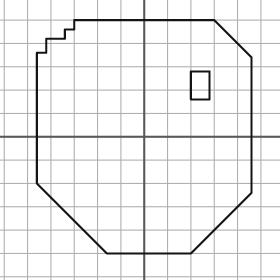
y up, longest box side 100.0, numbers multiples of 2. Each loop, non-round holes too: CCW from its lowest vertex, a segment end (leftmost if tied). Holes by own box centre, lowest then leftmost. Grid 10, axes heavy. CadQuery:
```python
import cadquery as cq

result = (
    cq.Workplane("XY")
    .moveTo(-16.0, -50.0)
    .lineTo(20.0, -50.0)
    .lineTo(46.0, -24.0)
    .lineTo(46.0, 34.0)
    .lineTo(30.0, 50.0)
    .lineTo(-30.0, 50.0)
    .lineTo(-30.0, 46.0)
    .lineTo(-34.0, 46.0)
    .lineTo(-34.0, 42.0)
    .lineTo(-42.0, 42.0)
    .lineTo(-42.0, 36.0)
    .lineTo(-46.0, 36.0)
    .lineTo(-46.0, -20.0)
    .close()
    .moveTo(20.0, 16.0)
    .lineTo(28.0, 16.0)
    .lineTo(28.0, 28.0)
    .lineTo(20.0, 28.0)
    .close()
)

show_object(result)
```